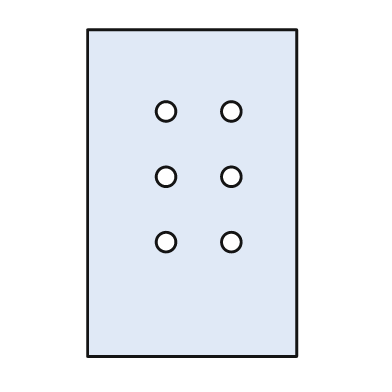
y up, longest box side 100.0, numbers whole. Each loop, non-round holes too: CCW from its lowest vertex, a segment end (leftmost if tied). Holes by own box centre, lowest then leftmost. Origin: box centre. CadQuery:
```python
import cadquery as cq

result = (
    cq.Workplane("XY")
    .moveTo(-32.0, -50.0)
    .lineTo(32.0, -50.0)
    .lineTo(32.0, 50.0)
    .lineTo(-32.0, 50.0)
    .close()
    .moveTo(-8.0, -15.0)
    .circle(3.0)
    .moveTo(12.0, -15.0)
    .circle(3.0)
    .moveTo(-8.0, 5.0)
    .circle(3.0)
    .moveTo(12.0, 5.0)
    .circle(3.0)
    .moveTo(-8.0, 25.0)
    .circle(3.0)
    .moveTo(12.0, 25.0)
    .circle(3.0)
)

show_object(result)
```